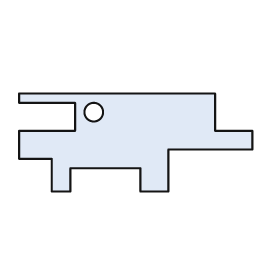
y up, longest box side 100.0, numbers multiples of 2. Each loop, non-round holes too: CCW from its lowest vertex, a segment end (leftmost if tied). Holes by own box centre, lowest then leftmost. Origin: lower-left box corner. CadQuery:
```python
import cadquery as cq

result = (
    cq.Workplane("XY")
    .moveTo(14.0, 0.0)
    .lineTo(22.0, 0.0)
    .lineTo(22.0, 10.0)
    .lineTo(52.0, 10.0)
    .lineTo(52.0, 0.0)
    .lineTo(64.0, 0.0)
    .lineTo(64.0, 18.0)
    .lineTo(100.0, 18.0)
    .lineTo(100.0, 26.0)
    .lineTo(84.0, 26.0)
    .lineTo(84.0, 42.0)
    .lineTo(0.0, 42.0)
    .lineTo(0.0, 38.0)
    .lineTo(24.0, 38.0)
    .lineTo(24.0, 26.0)
    .lineTo(0.0, 26.0)
    .lineTo(0.0, 14.0)
    .lineTo(14.0, 14.0)
    .close()
    .moveTo(32.0, 34.0)
    .circle(4.0)
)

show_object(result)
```